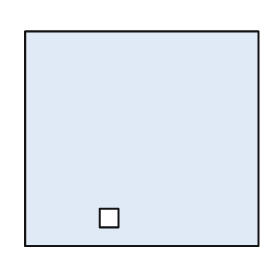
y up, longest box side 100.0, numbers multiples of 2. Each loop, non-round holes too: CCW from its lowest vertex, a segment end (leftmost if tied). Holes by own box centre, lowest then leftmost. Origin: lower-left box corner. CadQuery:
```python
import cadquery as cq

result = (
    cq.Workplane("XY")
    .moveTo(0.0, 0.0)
    .lineTo(100.0, 0.0)
    .lineTo(100.0, 92.0)
    .lineTo(0.0, 92.0)
    .close()
    .moveTo(32.0, 8.0)
    .lineTo(40.0, 8.0)
    .lineTo(40.0, 16.0)
    .lineTo(32.0, 16.0)
    .close()
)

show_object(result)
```